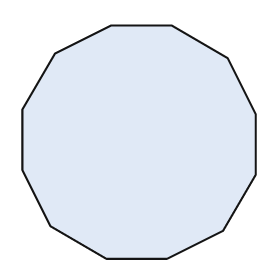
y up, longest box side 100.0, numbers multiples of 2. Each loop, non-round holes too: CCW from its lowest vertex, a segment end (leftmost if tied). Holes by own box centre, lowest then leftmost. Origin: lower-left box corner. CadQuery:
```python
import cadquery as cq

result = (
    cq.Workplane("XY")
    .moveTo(36.0, 0.0)
    .lineTo(62.0, 0.0)
    .lineTo(86.0, 12.0)
    .lineTo(100.0, 36.0)
    .lineTo(100.0, 62.0)
    .lineTo(88.0, 86.0)
    .lineTo(64.0, 100.0)
    .lineTo(38.0, 100.0)
    .lineTo(14.0, 88.0)
    .lineTo(0.0, 64.0)
    .lineTo(0.0, 38.0)
    .lineTo(12.0, 14.0)
    .close()
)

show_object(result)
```